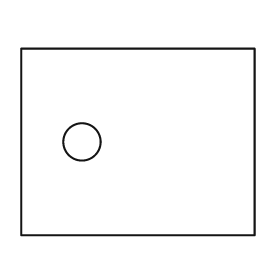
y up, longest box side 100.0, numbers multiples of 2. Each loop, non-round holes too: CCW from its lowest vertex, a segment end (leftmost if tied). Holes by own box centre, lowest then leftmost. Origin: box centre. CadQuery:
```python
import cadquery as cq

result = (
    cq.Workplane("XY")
    .moveTo(-50.0, -40.0)
    .lineTo(50.0, -40.0)
    .lineTo(50.0, 40.0)
    .lineTo(-50.0, 40.0)
    .close()
    .moveTo(-24.0, 0.0)
    .circle(8.0)
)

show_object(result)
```